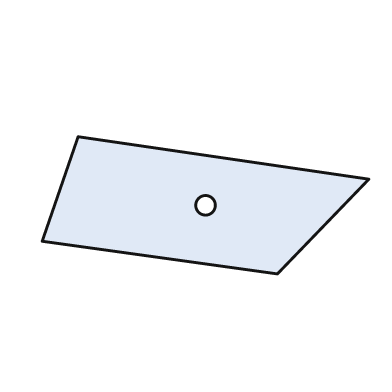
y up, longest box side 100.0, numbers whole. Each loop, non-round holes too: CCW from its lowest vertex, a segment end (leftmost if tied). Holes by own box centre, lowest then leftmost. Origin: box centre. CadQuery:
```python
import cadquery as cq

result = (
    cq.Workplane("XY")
    .moveTo(22.0, -21.0)
    .lineTo(50.0, 8.0)
    .lineTo(-39.0, 21.0)
    .lineTo(-50.0, -11.0)
    .close()
    .moveTo(0.0, 0.0)
    .circle(3.0)
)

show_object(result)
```